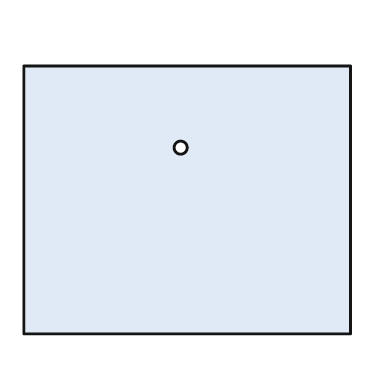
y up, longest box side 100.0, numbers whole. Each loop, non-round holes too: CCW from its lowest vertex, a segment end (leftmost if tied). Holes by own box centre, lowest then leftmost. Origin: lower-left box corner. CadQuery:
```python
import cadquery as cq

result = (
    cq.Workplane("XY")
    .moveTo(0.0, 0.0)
    .lineTo(100.0, 0.0)
    .lineTo(100.0, 82.0)
    .lineTo(0.0, 82.0)
    .close()
    .moveTo(48.0, 57.0)
    .circle(2.0)
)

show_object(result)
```